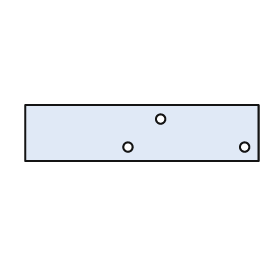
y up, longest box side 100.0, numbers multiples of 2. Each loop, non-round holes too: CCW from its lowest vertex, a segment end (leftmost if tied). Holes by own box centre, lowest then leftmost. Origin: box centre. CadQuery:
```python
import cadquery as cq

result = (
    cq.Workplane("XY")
    .moveTo(-50.0, -12.0)
    .lineTo(50.0, -12.0)
    .lineTo(50.0, 12.0)
    .lineTo(-50.0, 12.0)
    .close()
    .moveTo(-6.0, -6.0)
    .circle(2.0)
    .moveTo(44.0, -6.0)
    .circle(2.0)
    .moveTo(8.0, 6.0)
    .circle(2.0)
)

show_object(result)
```